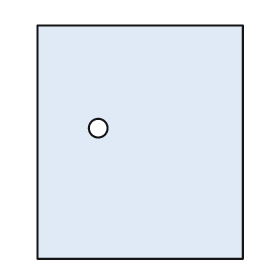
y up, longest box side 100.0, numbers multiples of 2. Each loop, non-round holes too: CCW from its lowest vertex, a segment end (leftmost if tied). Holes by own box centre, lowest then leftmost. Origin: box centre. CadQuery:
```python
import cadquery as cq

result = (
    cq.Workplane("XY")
    .moveTo(-44.0, -50.0)
    .lineTo(44.0, -50.0)
    .lineTo(44.0, 50.0)
    .lineTo(-44.0, 50.0)
    .close()
    .moveTo(-18.0, 6.0)
    .circle(4.0)
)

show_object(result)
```